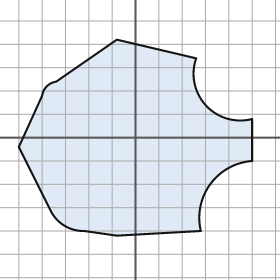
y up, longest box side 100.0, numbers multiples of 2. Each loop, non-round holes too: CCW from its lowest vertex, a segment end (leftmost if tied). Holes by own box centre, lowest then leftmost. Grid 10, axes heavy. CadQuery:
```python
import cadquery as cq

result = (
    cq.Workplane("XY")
    .moveTo(-8.0, -42.0)
    .lineTo(28.0, -40.0)
    .threePointArc((32.0, -20.0), (50.0, -10.0))
    .lineTo(50.0, 8.0)
    .threePointArc((30.0, 14.0), (26.0, 34.0))
    .lineTo(-8.0, 42.0)
    .lineTo(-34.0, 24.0)
    .threePointArc((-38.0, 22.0), (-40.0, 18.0))
    .lineTo(-50.0, -4.0)
    .lineTo(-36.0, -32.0)
    .threePointArc((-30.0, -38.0), (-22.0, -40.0))
    .close()
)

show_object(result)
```